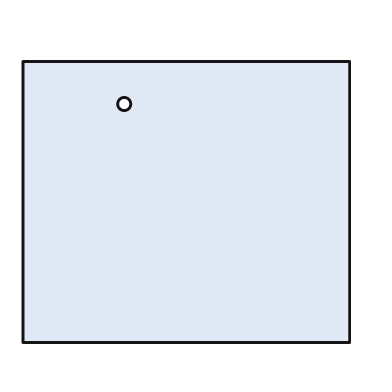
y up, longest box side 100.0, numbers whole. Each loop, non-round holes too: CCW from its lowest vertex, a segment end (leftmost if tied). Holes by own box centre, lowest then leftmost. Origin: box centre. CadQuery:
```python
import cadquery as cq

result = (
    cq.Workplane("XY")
    .moveTo(-50.0, -43.0)
    .lineTo(50.0, -43.0)
    .lineTo(50.0, 43.0)
    .lineTo(-50.0, 43.0)
    .close()
    .moveTo(-19.0, 30.0)
    .circle(2.0)
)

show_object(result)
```